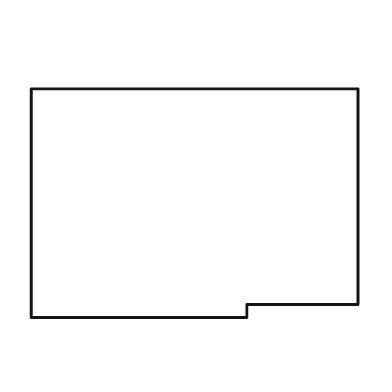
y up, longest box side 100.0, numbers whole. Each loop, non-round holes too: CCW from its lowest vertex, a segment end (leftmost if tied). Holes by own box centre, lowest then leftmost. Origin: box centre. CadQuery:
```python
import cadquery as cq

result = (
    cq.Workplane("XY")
    .moveTo(-50.0, -35.0)
    .lineTo(16.0, -35.0)
    .lineTo(16.0, -31.0)
    .lineTo(50.0, -31.0)
    .lineTo(50.0, 35.0)
    .lineTo(-50.0, 35.0)
    .close()
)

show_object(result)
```